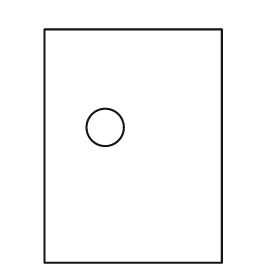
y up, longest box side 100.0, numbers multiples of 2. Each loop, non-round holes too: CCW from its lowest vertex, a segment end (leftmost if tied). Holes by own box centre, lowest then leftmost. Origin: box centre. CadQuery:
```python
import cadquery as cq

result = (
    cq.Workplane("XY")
    .moveTo(-38.0, -50.0)
    .lineTo(38.0, -50.0)
    .lineTo(38.0, 50.0)
    .lineTo(-38.0, 50.0)
    .close()
    .moveTo(-12.0, 8.0)
    .circle(8.0)
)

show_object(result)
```